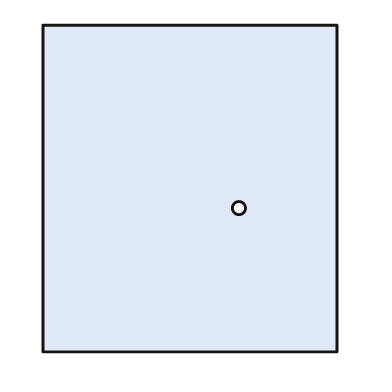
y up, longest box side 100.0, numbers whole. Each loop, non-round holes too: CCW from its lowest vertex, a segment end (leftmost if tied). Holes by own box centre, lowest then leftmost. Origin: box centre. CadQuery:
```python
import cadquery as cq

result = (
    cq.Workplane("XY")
    .moveTo(-45.0, -50.0)
    .lineTo(45.0, -50.0)
    .lineTo(45.0, 50.0)
    .lineTo(-45.0, 50.0)
    .close()
    .moveTo(15.0, -6.0)
    .circle(2.0)
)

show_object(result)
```